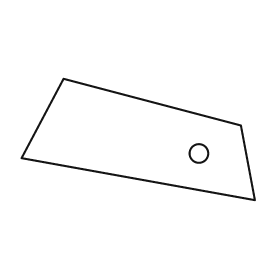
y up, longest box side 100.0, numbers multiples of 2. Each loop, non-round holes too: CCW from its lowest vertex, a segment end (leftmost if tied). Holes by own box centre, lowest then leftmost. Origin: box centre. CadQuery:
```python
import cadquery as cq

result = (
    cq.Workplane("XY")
    .moveTo(50.0, -26.0)
    .lineTo(44.0, 6.0)
    .lineTo(-32.0, 26.0)
    .lineTo(-50.0, -8.0)
    .close()
    .moveTo(26.0, -6.0)
    .circle(4.0)
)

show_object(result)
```